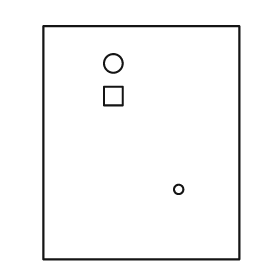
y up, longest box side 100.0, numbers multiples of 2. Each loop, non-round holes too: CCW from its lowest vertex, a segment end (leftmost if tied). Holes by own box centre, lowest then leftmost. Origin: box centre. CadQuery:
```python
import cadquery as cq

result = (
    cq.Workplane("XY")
    .moveTo(-42.0, -50.0)
    .lineTo(42.0, -50.0)
    .lineTo(42.0, 50.0)
    .lineTo(-42.0, 50.0)
    .close()
    .moveTo(16.0, -20.0)
    .circle(2.0)
    .moveTo(-16.0, 16.0)
    .lineTo(-8.0, 16.0)
    .lineTo(-8.0, 24.0)
    .lineTo(-16.0, 24.0)
    .close()
    .moveTo(-12.0, 34.0)
    .circle(4.0)
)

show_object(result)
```